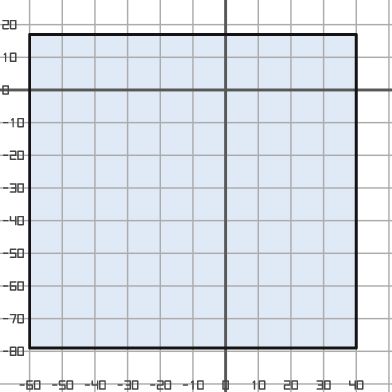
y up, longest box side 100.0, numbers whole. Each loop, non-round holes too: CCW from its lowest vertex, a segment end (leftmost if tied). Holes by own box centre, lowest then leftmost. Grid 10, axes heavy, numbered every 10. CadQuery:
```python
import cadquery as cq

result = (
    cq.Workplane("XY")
    .moveTo(-60.0, -79.0)
    .lineTo(40.0, -79.0)
    .lineTo(40.0, 17.0)
    .lineTo(-60.0, 17.0)
    .close()
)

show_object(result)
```